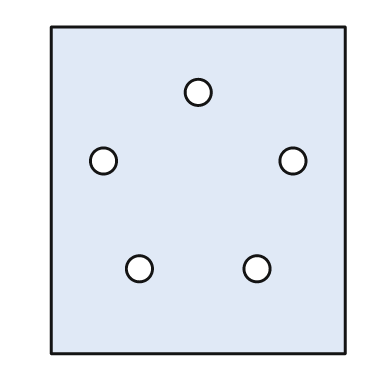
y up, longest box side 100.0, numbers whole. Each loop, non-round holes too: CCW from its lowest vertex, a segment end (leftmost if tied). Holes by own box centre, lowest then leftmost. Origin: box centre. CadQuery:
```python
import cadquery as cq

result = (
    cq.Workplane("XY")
    .moveTo(-45.0, -50.0)
    .lineTo(45.0, -50.0)
    .lineTo(45.0, 50.0)
    .lineTo(-45.0, 50.0)
    .close()
    .moveTo(-18.0, -24.0)
    .circle(4.0)
    .moveTo(18.0, -24.0)
    .circle(4.0)
    .moveTo(-29.0, 9.0)
    .circle(4.0)
    .moveTo(29.0, 9.0)
    .circle(4.0)
    .moveTo(0.0, 30.0)
    .circle(4.0)
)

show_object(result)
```